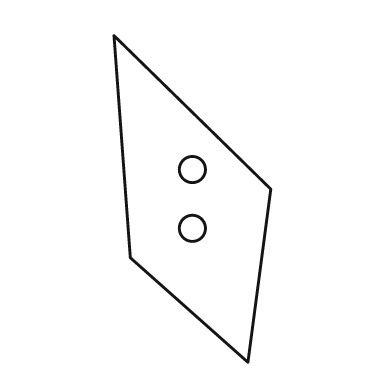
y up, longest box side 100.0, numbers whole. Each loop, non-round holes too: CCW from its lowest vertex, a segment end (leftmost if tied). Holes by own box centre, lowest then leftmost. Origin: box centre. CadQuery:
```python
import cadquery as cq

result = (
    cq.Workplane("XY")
    .moveTo(17.0, -50.0)
    .lineTo(24.0, 3.0)
    .lineTo(-24.0, 50.0)
    .lineTo(-19.0, -18.0)
    .close()
    .moveTo(0.0, -9.0)
    .circle(4.0)
    .moveTo(0.0, 9.0)
    .circle(4.0)
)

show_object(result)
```